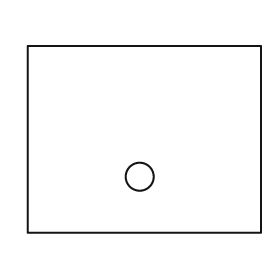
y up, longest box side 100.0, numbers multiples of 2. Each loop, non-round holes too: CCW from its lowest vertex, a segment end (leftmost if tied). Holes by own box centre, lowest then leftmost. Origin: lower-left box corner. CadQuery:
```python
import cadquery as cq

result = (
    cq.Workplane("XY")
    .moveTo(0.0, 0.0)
    .lineTo(100.0, 0.0)
    .lineTo(100.0, 80.0)
    .lineTo(0.0, 80.0)
    .close()
    .moveTo(48.0, 24.0)
    .circle(6.0)
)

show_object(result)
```